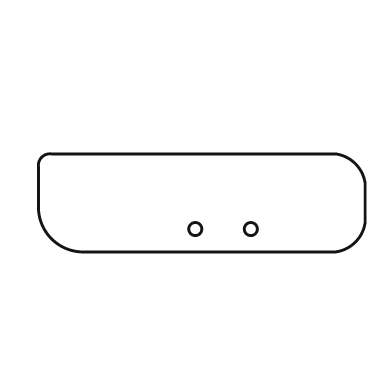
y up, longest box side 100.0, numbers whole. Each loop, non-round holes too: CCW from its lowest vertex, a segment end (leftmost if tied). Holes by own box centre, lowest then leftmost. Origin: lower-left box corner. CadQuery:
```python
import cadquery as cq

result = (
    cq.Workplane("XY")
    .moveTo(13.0, 0.0)
    .lineTo(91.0, 0.0)
    .threePointArc((97.0, 3.0), (100.0, 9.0))
    .lineTo(100.0, 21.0)
    .threePointArc((97.0, 27.0), (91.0, 30.0))
    .lineTo(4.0, 30.0)
    .threePointArc((1.0, 29.0), (0.0, 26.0))
    .lineTo(0.0, 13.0)
    .threePointArc((4.0, 4.0), (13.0, 0.0))
    .close()
    .moveTo(48.0, 7.0)
    .circle(2.0)
    .moveTo(65.0, 7.0)
    .circle(2.0)
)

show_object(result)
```